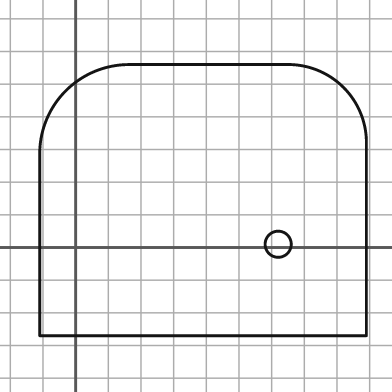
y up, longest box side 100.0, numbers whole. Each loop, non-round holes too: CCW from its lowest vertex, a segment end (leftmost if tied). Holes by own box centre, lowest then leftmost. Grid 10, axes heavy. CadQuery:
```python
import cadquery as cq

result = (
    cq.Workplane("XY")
    .moveTo(-11.0, -27.0)
    .lineTo(89.0, -27.0)
    .lineTo(89.0, 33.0)
    .threePointArc((82.0, 49.0), (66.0, 56.0))
    .lineTo(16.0, 56.0)
    .threePointArc((-3.0, 48.0), (-11.0, 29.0))
    .close()
    .moveTo(62.0, 1.0)
    .circle(4.0)
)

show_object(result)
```